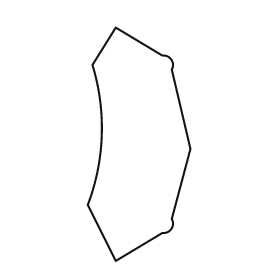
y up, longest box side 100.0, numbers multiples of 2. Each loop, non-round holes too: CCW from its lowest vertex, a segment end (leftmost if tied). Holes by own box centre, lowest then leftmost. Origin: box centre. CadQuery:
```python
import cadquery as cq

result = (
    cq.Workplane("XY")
    .moveTo(-10.0, -50.0)
    .lineTo(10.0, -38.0)
    .threePointArc((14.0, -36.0), (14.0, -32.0))
    .lineTo(22.0, -2.0)
    .lineTo(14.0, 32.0)
    .threePointArc((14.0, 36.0), (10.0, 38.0))
    .lineTo(-10.0, 50.0)
    .lineTo(-20.0, 34.0)
    .threePointArc((-16.0, 4.0), (-22.0, -26.0))
    .close()
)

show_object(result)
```